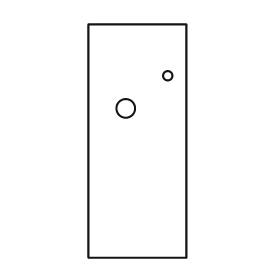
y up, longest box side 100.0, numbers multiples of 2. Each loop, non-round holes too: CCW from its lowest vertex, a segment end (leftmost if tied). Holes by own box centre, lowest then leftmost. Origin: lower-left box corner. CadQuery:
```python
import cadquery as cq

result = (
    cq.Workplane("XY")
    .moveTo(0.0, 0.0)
    .lineTo(42.0, 0.0)
    .lineTo(42.0, 100.0)
    .lineTo(0.0, 100.0)
    .close()
    .moveTo(16.0, 64.0)
    .circle(4.0)
    .moveTo(34.0, 78.0)
    .circle(2.0)
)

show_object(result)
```